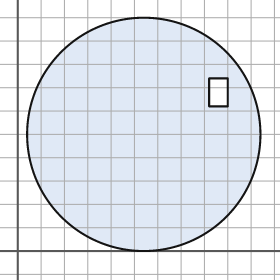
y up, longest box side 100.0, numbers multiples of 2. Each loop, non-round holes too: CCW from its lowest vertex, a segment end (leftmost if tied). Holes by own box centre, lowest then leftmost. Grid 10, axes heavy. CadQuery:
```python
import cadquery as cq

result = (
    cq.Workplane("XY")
    .moveTo(54.0, 50.0)
    .circle(50.0)
    .moveTo(82.0, 62.0)
    .lineTo(90.0, 62.0)
    .lineTo(90.0, 74.0)
    .lineTo(82.0, 74.0)
    .close()
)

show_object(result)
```